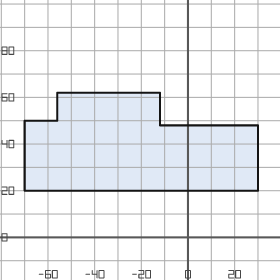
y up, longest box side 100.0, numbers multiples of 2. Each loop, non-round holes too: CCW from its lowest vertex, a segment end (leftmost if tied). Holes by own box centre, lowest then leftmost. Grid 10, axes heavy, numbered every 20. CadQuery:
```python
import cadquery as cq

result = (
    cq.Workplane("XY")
    .moveTo(-70.0, 20.0)
    .lineTo(30.0, 20.0)
    .lineTo(30.0, 48.0)
    .lineTo(-12.0, 48.0)
    .lineTo(-12.0, 62.0)
    .lineTo(-56.0, 62.0)
    .lineTo(-56.0, 50.0)
    .lineTo(-70.0, 50.0)
    .close()
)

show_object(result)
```